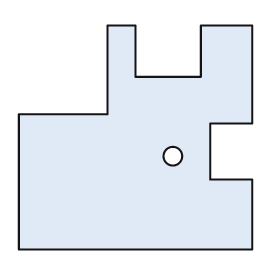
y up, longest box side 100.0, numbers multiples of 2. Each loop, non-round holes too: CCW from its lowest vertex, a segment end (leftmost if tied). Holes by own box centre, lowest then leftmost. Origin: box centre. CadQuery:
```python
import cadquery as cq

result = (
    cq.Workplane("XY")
    .moveTo(-50.0, -48.0)
    .lineTo(50.0, -48.0)
    .lineTo(50.0, -18.0)
    .lineTo(32.0, -18.0)
    .lineTo(32.0, 6.0)
    .lineTo(50.0, 6.0)
    .lineTo(50.0, 48.0)
    .lineTo(28.0, 48.0)
    .lineTo(28.0, 26.0)
    .lineTo(0.0, 26.0)
    .lineTo(0.0, 48.0)
    .lineTo(-12.0, 48.0)
    .lineTo(-12.0, 10.0)
    .lineTo(-50.0, 10.0)
    .close()
    .moveTo(16.0, -8.0)
    .circle(4.0)
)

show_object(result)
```